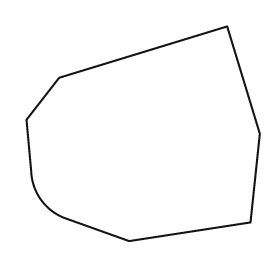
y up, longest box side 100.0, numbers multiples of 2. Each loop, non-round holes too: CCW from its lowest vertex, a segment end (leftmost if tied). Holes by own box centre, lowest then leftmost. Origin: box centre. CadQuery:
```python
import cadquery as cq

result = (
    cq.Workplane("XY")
    .moveTo(-6.0, -46.0)
    .lineTo(46.0, -38.0)
    .lineTo(50.0, 0.0)
    .lineTo(36.0, 46.0)
    .lineTo(-36.0, 24.0)
    .lineTo(-50.0, 6.0)
    .lineTo(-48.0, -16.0)
    .threePointArc((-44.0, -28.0), (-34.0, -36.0))
    .close()
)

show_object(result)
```